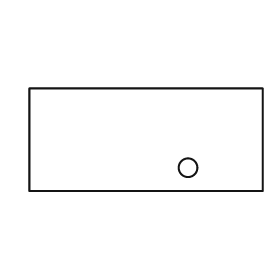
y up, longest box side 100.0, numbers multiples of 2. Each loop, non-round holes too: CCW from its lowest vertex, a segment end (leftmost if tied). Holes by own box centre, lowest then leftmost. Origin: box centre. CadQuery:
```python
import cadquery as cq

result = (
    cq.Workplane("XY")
    .moveTo(-50.0, -22.0)
    .lineTo(50.0, -22.0)
    .lineTo(50.0, 22.0)
    .lineTo(-50.0, 22.0)
    .close()
    .moveTo(18.0, -12.0)
    .circle(4.0)
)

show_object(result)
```